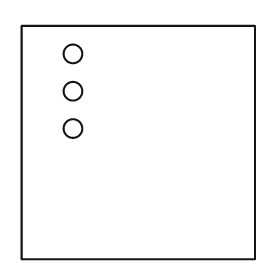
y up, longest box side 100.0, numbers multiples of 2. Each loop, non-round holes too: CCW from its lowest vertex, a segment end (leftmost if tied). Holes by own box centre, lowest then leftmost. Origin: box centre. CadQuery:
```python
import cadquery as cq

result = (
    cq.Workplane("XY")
    .moveTo(-50.0, -50.0)
    .lineTo(50.0, -50.0)
    .lineTo(50.0, 50.0)
    .lineTo(-50.0, 50.0)
    .close()
    .moveTo(-28.0, 6.0)
    .circle(4.0)
    .moveTo(-28.0, 22.0)
    .circle(4.0)
    .moveTo(-28.0, 38.0)
    .circle(4.0)
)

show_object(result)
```